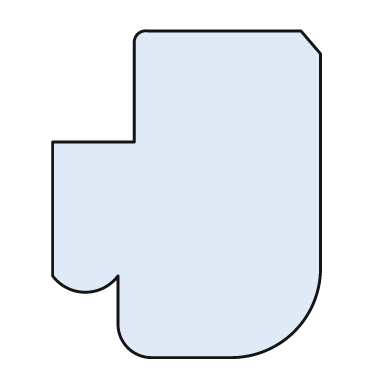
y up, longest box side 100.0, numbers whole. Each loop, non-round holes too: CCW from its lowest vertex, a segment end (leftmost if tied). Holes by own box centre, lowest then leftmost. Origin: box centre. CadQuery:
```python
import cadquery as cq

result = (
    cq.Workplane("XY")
    .moveTo(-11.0, -50.0)
    .lineTo(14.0, -50.0)
    .threePointArc((33.0, -42.0), (41.0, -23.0))
    .lineTo(41.0, 43.0)
    .lineTo(35.0, 50.0)
    .lineTo(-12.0, 50.0)
    .threePointArc((-15.0, 49.0), (-16.0, 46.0))
    .lineTo(-16.0, 16.0)
    .lineTo(-41.0, 16.0)
    .lineTo(-41.0, -25.0)
    .threePointArc((-31.0, -30.0), (-21.0, -25.0))
    .lineTo(-21.0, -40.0)
    .threePointArc((-18.0, -47.0), (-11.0, -50.0))
    .close()
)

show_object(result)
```